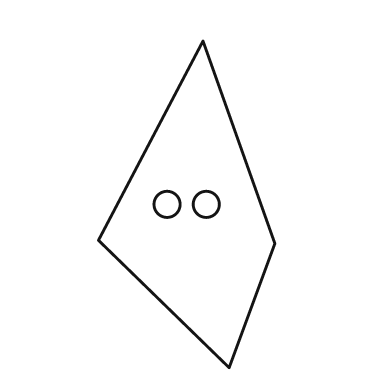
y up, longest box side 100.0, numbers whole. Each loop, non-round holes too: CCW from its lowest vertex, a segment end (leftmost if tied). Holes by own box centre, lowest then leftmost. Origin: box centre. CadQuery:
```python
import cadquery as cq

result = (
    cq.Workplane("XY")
    .moveTo(13.0, -50.0)
    .lineTo(27.0, -12.0)
    .lineTo(5.0, 50.0)
    .lineTo(-27.0, -11.0)
    .close()
    .moveTo(-6.0, 0.0)
    .circle(4.0)
    .moveTo(6.0, 0.0)
    .circle(4.0)
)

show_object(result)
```